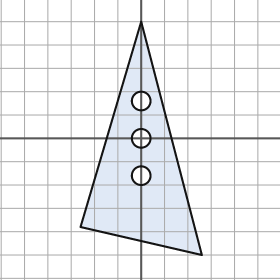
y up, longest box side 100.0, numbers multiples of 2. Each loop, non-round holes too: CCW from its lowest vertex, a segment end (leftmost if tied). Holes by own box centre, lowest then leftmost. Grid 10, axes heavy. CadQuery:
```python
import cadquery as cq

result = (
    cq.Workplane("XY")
    .moveTo(26.0, -50.0)
    .lineTo(0.0, 50.0)
    .lineTo(-26.0, -38.0)
    .close()
    .moveTo(0.0, -16.0)
    .circle(4.0)
    .moveTo(0.0, 0.0)
    .circle(4.0)
    .moveTo(0.0, 16.0)
    .circle(4.0)
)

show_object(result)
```